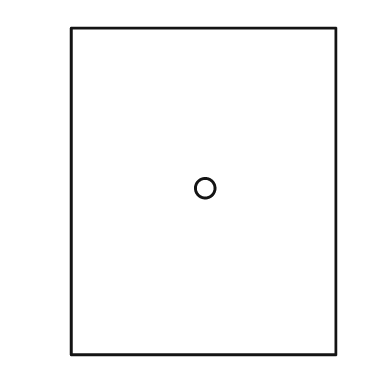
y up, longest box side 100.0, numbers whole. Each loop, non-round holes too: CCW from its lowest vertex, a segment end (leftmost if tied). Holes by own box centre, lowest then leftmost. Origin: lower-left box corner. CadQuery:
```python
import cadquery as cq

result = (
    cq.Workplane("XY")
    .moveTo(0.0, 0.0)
    .lineTo(81.0, 0.0)
    .lineTo(81.0, 100.0)
    .lineTo(0.0, 100.0)
    .close()
    .moveTo(41.0, 51.0)
    .circle(3.0)
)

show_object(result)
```